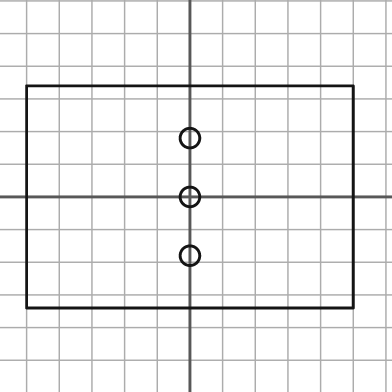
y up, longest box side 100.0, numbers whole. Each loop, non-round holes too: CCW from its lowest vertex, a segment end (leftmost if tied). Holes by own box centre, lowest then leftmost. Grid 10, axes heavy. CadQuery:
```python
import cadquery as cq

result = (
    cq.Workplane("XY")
    .moveTo(-50.0, -34.0)
    .lineTo(50.0, -34.0)
    .lineTo(50.0, 34.0)
    .lineTo(-50.0, 34.0)
    .close()
    .moveTo(0.0, -18.0)
    .circle(3.0)
    .moveTo(0.0, 0.0)
    .circle(3.0)
    .moveTo(0.0, 18.0)
    .circle(3.0)
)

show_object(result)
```